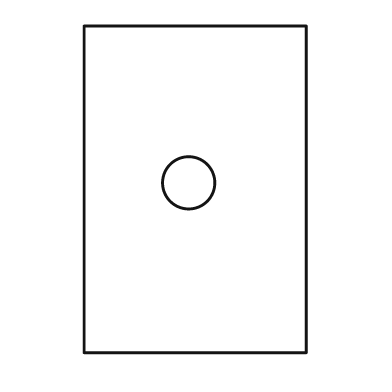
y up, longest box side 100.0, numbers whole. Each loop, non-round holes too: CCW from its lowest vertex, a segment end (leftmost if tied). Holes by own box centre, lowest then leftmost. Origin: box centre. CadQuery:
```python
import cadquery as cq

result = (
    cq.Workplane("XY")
    .moveTo(-34.0, -50.0)
    .lineTo(34.0, -50.0)
    .lineTo(34.0, 50.0)
    .lineTo(-34.0, 50.0)
    .close()
    .moveTo(-2.0, 2.0)
    .circle(8.0)
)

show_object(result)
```